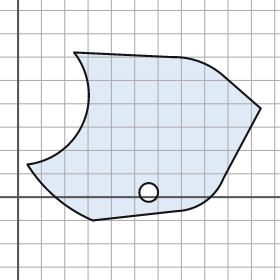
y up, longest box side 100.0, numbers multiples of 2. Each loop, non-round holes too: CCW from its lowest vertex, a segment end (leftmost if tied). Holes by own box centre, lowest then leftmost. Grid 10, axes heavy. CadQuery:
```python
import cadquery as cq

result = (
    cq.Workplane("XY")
    .moveTo(32.0, -10.0)
    .lineTo(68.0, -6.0)
    .threePointArc((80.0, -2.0), (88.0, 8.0))
    .lineTo(104.0, 38.0)
    .lineTo(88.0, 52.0)
    .threePointArc((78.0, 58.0), (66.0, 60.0))
    .lineTo(24.0, 62.0)
    .threePointArc((28.0, 32.0), (4.0, 14.0))
    .threePointArc((16.0, 0.0), (32.0, -10.0))
    .close()
    .moveTo(56.0, 2.0)
    .circle(4.0)
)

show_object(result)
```